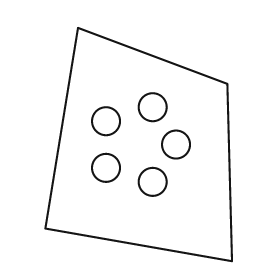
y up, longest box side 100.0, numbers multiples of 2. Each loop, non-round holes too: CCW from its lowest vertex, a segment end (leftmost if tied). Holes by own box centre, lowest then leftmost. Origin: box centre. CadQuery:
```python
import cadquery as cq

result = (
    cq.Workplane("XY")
    .moveTo(40.0, -50.0)
    .lineTo(38.0, 26.0)
    .lineTo(-26.0, 50.0)
    .lineTo(-40.0, -36.0)
    .close()
    .moveTo(6.0, -16.0)
    .circle(6.0)
    .moveTo(-14.0, -10.0)
    .circle(6.0)
    .moveTo(16.0, 0.0)
    .circle(6.0)
    .moveTo(-14.0, 10.0)
    .circle(6.0)
    .moveTo(6.0, 16.0)
    .circle(6.0)
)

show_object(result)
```